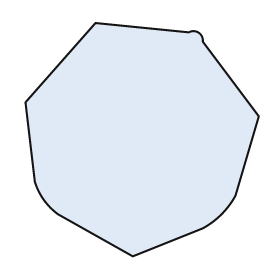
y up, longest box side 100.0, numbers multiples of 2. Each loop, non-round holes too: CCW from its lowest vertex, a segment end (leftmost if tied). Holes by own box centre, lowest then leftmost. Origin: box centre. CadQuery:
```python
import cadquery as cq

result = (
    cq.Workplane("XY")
    .moveTo(-4.0, -50.0)
    .lineTo(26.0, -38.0)
    .threePointArc((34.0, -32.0), (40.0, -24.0))
    .lineTo(50.0, 10.0)
    .lineTo(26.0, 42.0)
    .threePointArc((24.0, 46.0), (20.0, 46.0))
    .lineTo(-20.0, 50.0)
    .lineTo(-50.0, 16.0)
    .lineTo(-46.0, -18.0)
    .threePointArc((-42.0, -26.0), (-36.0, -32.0))
    .close()
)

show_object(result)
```